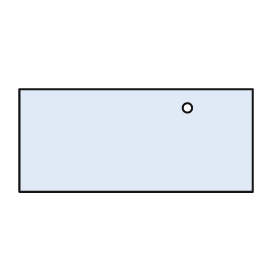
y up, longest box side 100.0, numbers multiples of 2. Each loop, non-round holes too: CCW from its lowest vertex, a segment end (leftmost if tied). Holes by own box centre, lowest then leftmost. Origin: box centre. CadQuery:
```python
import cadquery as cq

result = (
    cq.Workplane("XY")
    .moveTo(-50.0, -22.0)
    .lineTo(50.0, -22.0)
    .lineTo(50.0, 22.0)
    .lineTo(-50.0, 22.0)
    .close()
    .moveTo(22.0, 14.0)
    .circle(2.0)
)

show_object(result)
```